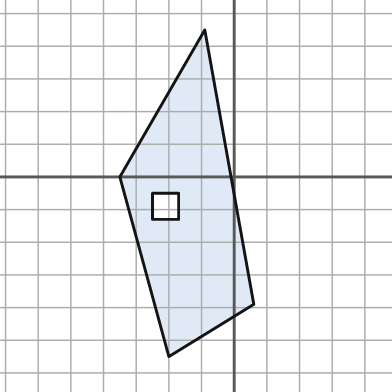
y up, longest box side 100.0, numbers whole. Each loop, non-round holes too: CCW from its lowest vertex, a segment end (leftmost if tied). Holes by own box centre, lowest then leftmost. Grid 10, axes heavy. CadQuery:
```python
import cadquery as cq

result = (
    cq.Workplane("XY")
    .moveTo(-20.0, -55.0)
    .lineTo(6.0, -39.0)
    .lineTo(-9.0, 45.0)
    .lineTo(-35.0, 0.0)
    .close()
    .moveTo(-25.0, -13.0)
    .lineTo(-17.0, -13.0)
    .lineTo(-17.0, -5.0)
    .lineTo(-25.0, -5.0)
    .close()
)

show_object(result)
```